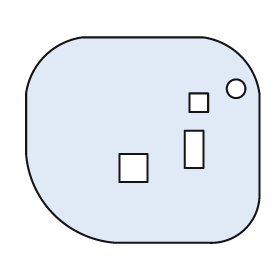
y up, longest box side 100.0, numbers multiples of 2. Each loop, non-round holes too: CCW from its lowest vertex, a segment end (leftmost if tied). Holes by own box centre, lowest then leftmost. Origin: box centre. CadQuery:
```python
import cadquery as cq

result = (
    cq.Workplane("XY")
    .moveTo(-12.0, -44.0)
    .lineTo(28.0, -44.0)
    .threePointArc((44.0, -38.0), (50.0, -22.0))
    .lineTo(50.0, 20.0)
    .threePointArc((42.0, 36.0), (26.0, 44.0))
    .lineTo(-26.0, 44.0)
    .threePointArc((-42.0, 36.0), (-50.0, 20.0))
    .lineTo(-50.0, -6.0)
    .threePointArc((-38.0, -32.0), (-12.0, -44.0))
    .close()
    .moveTo(-10.0, -18.0)
    .lineTo(2.0, -18.0)
    .lineTo(2.0, -6.0)
    .lineTo(-10.0, -6.0)
    .close()
    .moveTo(18.0, -12.0)
    .lineTo(26.0, -12.0)
    .lineTo(26.0, 4.0)
    .lineTo(18.0, 4.0)
    .close()
    .moveTo(20.0, 12.0)
    .lineTo(28.0, 12.0)
    .lineTo(28.0, 20.0)
    .lineTo(20.0, 20.0)
    .close()
    .moveTo(40.0, 22.0)
    .circle(4.0)
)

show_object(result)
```